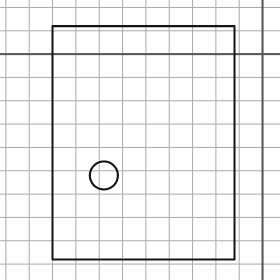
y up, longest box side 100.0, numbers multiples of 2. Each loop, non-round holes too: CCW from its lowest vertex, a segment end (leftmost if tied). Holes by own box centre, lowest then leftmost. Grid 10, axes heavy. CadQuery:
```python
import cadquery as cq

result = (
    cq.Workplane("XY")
    .moveTo(-90.0, -88.0)
    .lineTo(-12.0, -88.0)
    .lineTo(-12.0, 12.0)
    .lineTo(-90.0, 12.0)
    .close()
    .moveTo(-68.0, -52.0)
    .circle(6.0)
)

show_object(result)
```